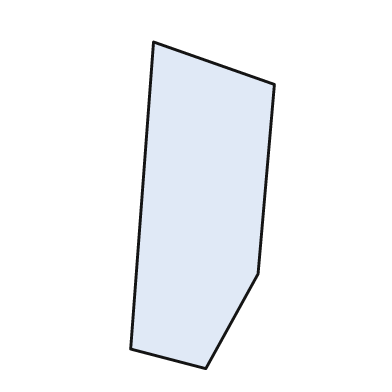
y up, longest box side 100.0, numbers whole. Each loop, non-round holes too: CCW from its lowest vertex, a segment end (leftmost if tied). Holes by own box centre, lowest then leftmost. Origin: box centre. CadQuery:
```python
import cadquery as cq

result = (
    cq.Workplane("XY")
    .moveTo(1.0, -50.0)
    .lineTo(17.0, -21.0)
    .lineTo(22.0, 37.0)
    .lineTo(-15.0, 50.0)
    .lineTo(-22.0, -44.0)
    .close()
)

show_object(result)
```